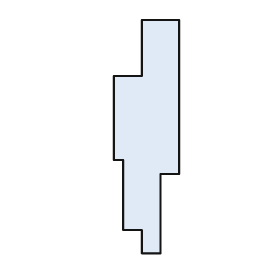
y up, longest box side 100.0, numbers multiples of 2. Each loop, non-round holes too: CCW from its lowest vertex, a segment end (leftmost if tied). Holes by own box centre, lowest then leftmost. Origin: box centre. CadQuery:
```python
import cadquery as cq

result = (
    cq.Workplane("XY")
    .moveTo(-2.0, -50.0)
    .lineTo(6.0, -50.0)
    .lineTo(6.0, -16.0)
    .lineTo(14.0, -16.0)
    .lineTo(14.0, 50.0)
    .lineTo(-2.0, 50.0)
    .lineTo(-2.0, 26.0)
    .lineTo(-14.0, 26.0)
    .lineTo(-14.0, -10.0)
    .lineTo(-10.0, -10.0)
    .lineTo(-10.0, -40.0)
    .lineTo(-2.0, -40.0)
    .close()
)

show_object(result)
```